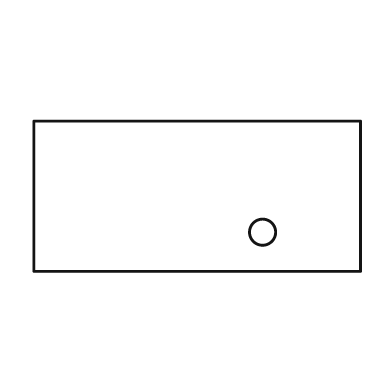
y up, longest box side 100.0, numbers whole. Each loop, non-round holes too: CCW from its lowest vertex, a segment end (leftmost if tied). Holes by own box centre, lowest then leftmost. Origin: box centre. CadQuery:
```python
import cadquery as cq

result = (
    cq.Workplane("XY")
    .moveTo(-50.0, -23.0)
    .lineTo(50.0, -23.0)
    .lineTo(50.0, 23.0)
    .lineTo(-50.0, 23.0)
    .close()
    .moveTo(20.0, -11.0)
    .circle(4.0)
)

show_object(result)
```